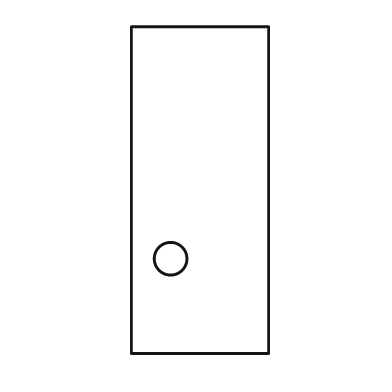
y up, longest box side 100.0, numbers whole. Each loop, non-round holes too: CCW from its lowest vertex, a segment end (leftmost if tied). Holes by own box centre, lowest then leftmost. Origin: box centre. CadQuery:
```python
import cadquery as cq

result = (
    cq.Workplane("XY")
    .moveTo(-21.0, -50.0)
    .lineTo(21.0, -50.0)
    .lineTo(21.0, 50.0)
    .lineTo(-21.0, 50.0)
    .close()
    .moveTo(-9.0, -21.0)
    .circle(5.0)
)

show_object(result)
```